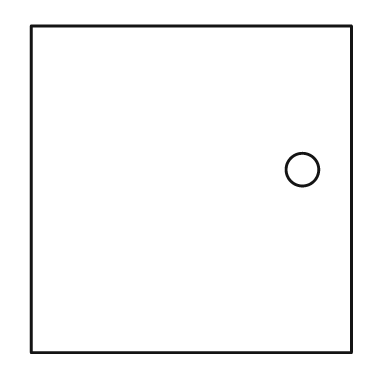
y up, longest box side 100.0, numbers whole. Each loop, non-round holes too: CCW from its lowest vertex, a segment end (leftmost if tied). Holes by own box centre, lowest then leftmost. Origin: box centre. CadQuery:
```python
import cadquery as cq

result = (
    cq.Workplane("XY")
    .moveTo(-49.0, -50.0)
    .lineTo(49.0, -50.0)
    .lineTo(49.0, 50.0)
    .lineTo(-49.0, 50.0)
    .close()
    .moveTo(34.0, 6.0)
    .circle(5.0)
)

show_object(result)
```